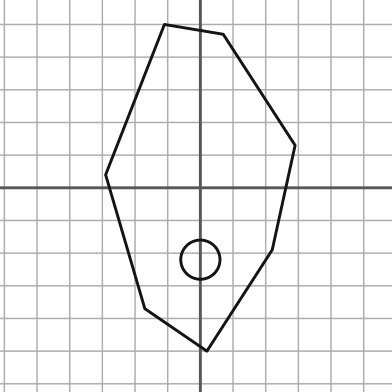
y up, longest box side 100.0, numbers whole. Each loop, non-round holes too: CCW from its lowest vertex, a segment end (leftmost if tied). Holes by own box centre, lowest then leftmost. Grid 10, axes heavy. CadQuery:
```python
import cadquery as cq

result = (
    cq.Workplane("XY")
    .moveTo(2.0, -50.0)
    .lineTo(22.0, -19.0)
    .lineTo(29.0, 13.0)
    .lineTo(7.0, 47.0)
    .lineTo(-11.0, 50.0)
    .lineTo(-29.0, 4.0)
    .lineTo(-17.0, -37.0)
    .close()
    .moveTo(0.0, -22.0)
    .circle(6.0)
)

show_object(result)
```